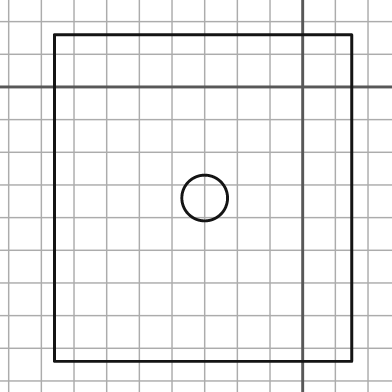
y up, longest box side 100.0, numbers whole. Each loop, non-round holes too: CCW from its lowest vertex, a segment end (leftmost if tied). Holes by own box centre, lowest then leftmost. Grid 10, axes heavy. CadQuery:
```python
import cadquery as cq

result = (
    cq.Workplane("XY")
    .moveTo(-76.0, -84.0)
    .lineTo(15.0, -84.0)
    .lineTo(15.0, 16.0)
    .lineTo(-76.0, 16.0)
    .close()
    .moveTo(-30.0, -34.0)
    .circle(7.0)
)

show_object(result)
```